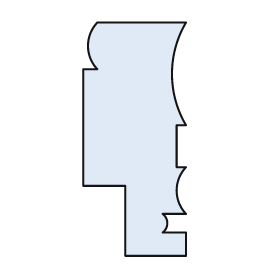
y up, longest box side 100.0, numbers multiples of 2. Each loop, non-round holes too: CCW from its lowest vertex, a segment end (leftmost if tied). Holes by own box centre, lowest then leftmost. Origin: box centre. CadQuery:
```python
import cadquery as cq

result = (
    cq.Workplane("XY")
    .moveTo(-4.0, -50.0)
    .lineTo(22.0, -50.0)
    .lineTo(22.0, -40.0)
    .lineTo(12.0, -40.0)
    .threePointArc((14.0, -36.0), (12.0, -32.0))
    .lineTo(22.0, -32.0)
    .threePointArc((18.0, -22.0), (22.0, -12.0))
    .lineTo(18.0, -12.0)
    .lineTo(18.0, 6.0)
    .lineTo(22.0, 6.0)
    .threePointArc((16.0, 28.0), (22.0, 50.0))
    .lineTo(-16.0, 50.0)
    .threePointArc((-20.0, 40.0), (-16.0, 30.0))
    .lineTo(-22.0, 30.0)
    .lineTo(-22.0, -20.0)
    .lineTo(-4.0, -20.0)
    .close()
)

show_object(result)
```